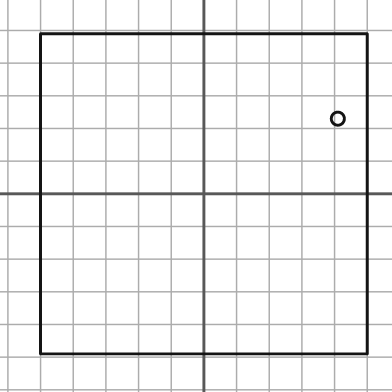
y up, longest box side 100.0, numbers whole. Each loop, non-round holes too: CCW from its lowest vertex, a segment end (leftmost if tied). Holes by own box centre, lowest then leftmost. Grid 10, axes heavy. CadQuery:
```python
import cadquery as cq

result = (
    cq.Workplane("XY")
    .moveTo(-50.0, -49.0)
    .lineTo(50.0, -49.0)
    .lineTo(50.0, 49.0)
    .lineTo(-50.0, 49.0)
    .close()
    .moveTo(41.0, 23.0)
    .circle(2.0)
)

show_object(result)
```